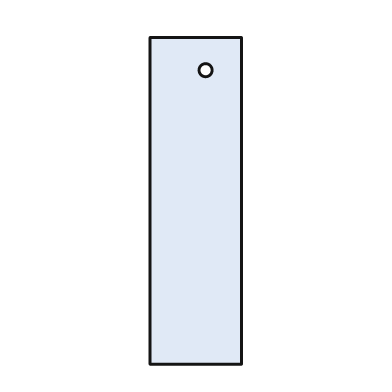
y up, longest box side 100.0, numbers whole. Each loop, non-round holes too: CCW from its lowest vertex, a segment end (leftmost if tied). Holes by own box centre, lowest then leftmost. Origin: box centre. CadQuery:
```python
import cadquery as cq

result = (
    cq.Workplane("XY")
    .moveTo(-14.0, -50.0)
    .lineTo(14.0, -50.0)
    .lineTo(14.0, 50.0)
    .lineTo(-14.0, 50.0)
    .close()
    .moveTo(3.0, 40.0)
    .circle(2.0)
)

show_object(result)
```